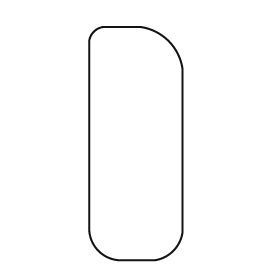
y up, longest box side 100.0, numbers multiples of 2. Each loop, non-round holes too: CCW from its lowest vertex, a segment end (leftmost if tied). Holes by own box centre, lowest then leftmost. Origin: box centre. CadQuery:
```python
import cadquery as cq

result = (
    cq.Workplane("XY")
    .moveTo(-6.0, -50.0)
    .lineTo(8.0, -50.0)
    .threePointArc((16.0, -46.0), (20.0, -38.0))
    .lineTo(20.0, 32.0)
    .threePointArc((14.0, 44.0), (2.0, 50.0))
    .lineTo(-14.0, 50.0)
    .threePointArc((-18.0, 48.0), (-20.0, 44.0))
    .lineTo(-20.0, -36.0)
    .threePointArc((-16.0, -46.0), (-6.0, -50.0))
    .close()
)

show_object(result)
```